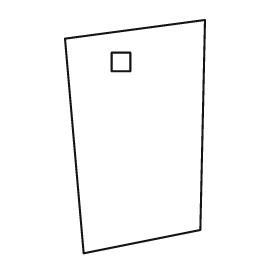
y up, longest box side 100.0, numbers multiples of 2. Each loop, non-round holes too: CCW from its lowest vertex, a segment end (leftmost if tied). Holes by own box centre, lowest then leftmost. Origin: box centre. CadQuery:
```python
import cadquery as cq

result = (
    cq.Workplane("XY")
    .moveTo(-22.0, -50.0)
    .lineTo(28.0, -40.0)
    .lineTo(30.0, 50.0)
    .lineTo(-30.0, 42.0)
    .close()
    .moveTo(-10.0, 28.0)
    .lineTo(-2.0, 28.0)
    .lineTo(-2.0, 36.0)
    .lineTo(-10.0, 36.0)
    .close()
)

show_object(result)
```